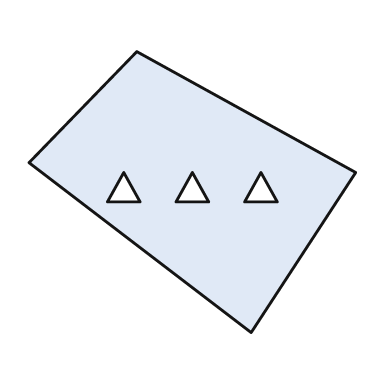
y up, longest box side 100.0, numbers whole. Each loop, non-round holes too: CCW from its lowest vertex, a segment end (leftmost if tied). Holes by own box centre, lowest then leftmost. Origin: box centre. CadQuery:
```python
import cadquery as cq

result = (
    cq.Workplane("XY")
    .moveTo(18.0, -43.0)
    .lineTo(50.0, 6.0)
    .lineTo(-17.0, 43.0)
    .lineTo(-50.0, 9.0)
    .close()
    .moveTo(-26.0, -3.0)
    .lineTo(-16.0, -3.0)
    .lineTo(-21.0, 6.0)
    .close()
    .moveTo(-5.0, -3.0)
    .lineTo(5.0, -3.0)
    .lineTo(0.0, 6.0)
    .close()
    .moveTo(16.0, -3.0)
    .lineTo(26.0, -3.0)
    .lineTo(21.0, 6.0)
    .close()
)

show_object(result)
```